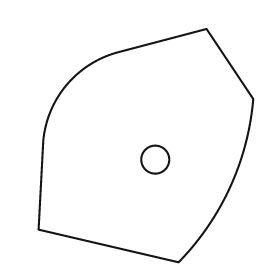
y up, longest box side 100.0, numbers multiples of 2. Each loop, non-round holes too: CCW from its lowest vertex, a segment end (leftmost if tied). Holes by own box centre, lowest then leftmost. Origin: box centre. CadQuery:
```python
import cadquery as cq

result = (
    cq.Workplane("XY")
    .moveTo(14.0, -50.0)
    .threePointArc((36.0, -18.0), (46.0, 20.0))
    .lineTo(26.0, 50.0)
    .lineTo(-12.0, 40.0)
    .threePointArc((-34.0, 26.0), (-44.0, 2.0))
    .lineTo(-46.0, -36.0)
    .close()
    .moveTo(4.0, -6.0)
    .circle(6.0)
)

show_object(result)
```